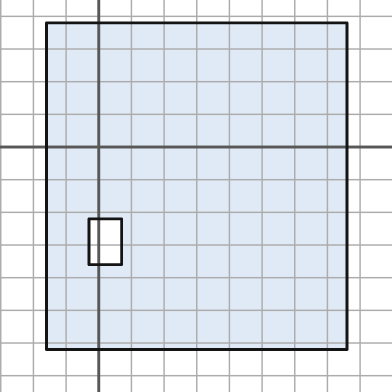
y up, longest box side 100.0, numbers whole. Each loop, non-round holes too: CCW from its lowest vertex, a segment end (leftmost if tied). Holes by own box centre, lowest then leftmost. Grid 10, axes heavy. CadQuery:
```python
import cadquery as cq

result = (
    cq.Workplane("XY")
    .moveTo(-16.0, -62.0)
    .lineTo(76.0, -62.0)
    .lineTo(76.0, 38.0)
    .lineTo(-16.0, 38.0)
    .close()
    .moveTo(-3.0, -36.0)
    .lineTo(7.0, -36.0)
    .lineTo(7.0, -22.0)
    .lineTo(-3.0, -22.0)
    .close()
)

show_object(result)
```